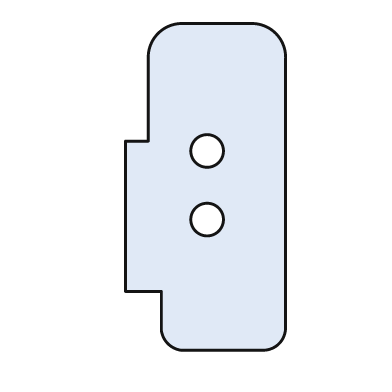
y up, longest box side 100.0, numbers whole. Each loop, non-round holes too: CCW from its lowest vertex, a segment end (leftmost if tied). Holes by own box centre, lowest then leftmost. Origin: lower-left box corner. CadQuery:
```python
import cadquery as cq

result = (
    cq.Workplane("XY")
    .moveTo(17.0, 0.0)
    .lineTo(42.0, 0.0)
    .threePointArc((47.0, 2.0), (49.0, 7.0))
    .lineTo(49.0, 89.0)
    .threePointArc((46.0, 97.0), (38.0, 100.0))
    .lineTo(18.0, 100.0)
    .threePointArc((10.0, 97.0), (7.0, 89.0))
    .lineTo(7.0, 64.0)
    .lineTo(0.0, 64.0)
    .lineTo(0.0, 18.0)
    .lineTo(11.0, 18.0)
    .lineTo(11.0, 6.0)
    .threePointArc((13.0, 2.0), (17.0, 0.0))
    .close()
    .moveTo(25.0, 40.0)
    .circle(5.0)
    .moveTo(25.0, 61.0)
    .circle(5.0)
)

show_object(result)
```